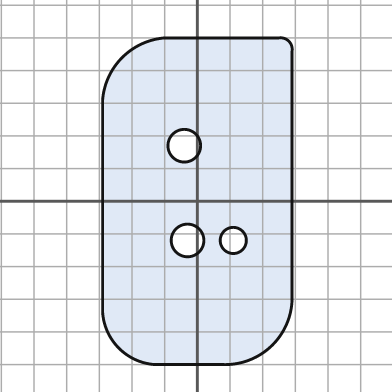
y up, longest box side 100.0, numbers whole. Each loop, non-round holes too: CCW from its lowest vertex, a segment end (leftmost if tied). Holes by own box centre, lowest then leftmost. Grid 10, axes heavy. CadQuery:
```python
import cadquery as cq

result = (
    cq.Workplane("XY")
    .moveTo(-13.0, -50.0)
    .lineTo(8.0, -50.0)
    .threePointArc((23.0, -44.0), (29.0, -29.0))
    .lineTo(29.0, 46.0)
    .threePointArc((28.0, 49.0), (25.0, 50.0))
    .lineTo(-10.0, 50.0)
    .threePointArc((-23.0, 44.0), (-29.0, 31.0))
    .lineTo(-29.0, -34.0)
    .threePointArc((-24.0, -45.0), (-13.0, -50.0))
    .close()
    .moveTo(-3.0, -12.0)
    .circle(5.0)
    .moveTo(11.0, -12.0)
    .circle(4.0)
    .moveTo(-4.0, 17.0)
    .circle(5.0)
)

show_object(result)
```